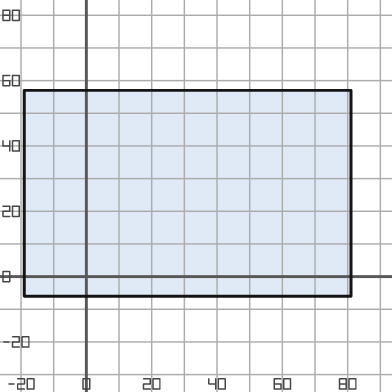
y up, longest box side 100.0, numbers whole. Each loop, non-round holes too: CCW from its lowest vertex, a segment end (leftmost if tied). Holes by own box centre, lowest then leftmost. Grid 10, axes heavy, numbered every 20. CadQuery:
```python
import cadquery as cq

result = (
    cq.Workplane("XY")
    .moveTo(-19.0, -6.0)
    .lineTo(81.0, -6.0)
    .lineTo(81.0, 57.0)
    .lineTo(-19.0, 57.0)
    .close()
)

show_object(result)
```